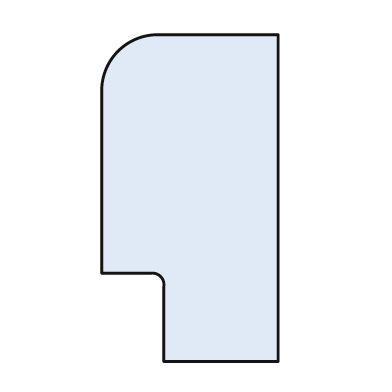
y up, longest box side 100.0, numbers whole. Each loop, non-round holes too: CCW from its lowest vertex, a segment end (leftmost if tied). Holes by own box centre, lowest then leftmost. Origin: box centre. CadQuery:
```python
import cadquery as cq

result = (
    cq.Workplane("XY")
    .moveTo(-8.0, -50.0)
    .lineTo(27.0, -50.0)
    .lineTo(27.0, 50.0)
    .lineTo(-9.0, 50.0)
    .threePointArc((-22.0, 45.0), (-27.0, 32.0))
    .lineTo(-27.0, -23.0)
    .lineTo(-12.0, -23.0)
    .threePointArc((-9.0, -24.0), (-8.0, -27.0))
    .close()
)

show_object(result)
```